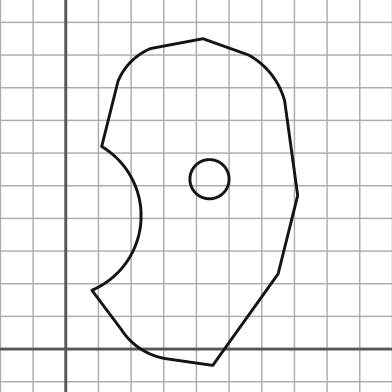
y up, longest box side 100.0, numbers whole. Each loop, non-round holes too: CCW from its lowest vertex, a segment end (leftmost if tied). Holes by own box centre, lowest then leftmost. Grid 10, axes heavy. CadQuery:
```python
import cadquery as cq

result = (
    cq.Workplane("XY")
    .moveTo(45.0, -5.0)
    .lineTo(65.0, 23.0)
    .lineTo(71.0, 47.0)
    .lineTo(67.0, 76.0)
    .threePointArc((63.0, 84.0), (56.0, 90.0))
    .lineTo(42.0, 95.0)
    .lineTo(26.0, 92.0)
    .threePointArc((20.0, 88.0), (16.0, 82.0))
    .lineTo(11.0, 62.0)
    .threePointArc((23.0, 39.0), (8.0, 18.0))
    .lineTo(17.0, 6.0)
    .threePointArc((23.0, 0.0), (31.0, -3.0))
    .close()
    .moveTo(44.0, 52.0)
    .circle(6.0)
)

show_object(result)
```